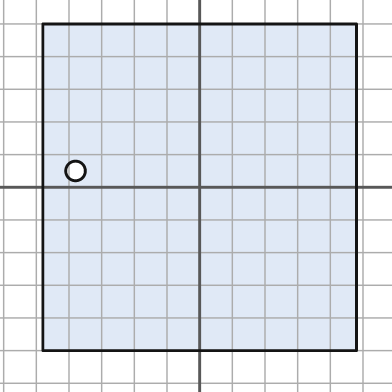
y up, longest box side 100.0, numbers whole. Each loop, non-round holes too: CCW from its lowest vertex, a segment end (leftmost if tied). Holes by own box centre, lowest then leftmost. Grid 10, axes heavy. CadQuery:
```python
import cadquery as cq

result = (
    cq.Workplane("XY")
    .moveTo(-48.0, -50.0)
    .lineTo(48.0, -50.0)
    .lineTo(48.0, 50.0)
    .lineTo(-48.0, 50.0)
    .close()
    .moveTo(-38.0, 5.0)
    .circle(3.0)
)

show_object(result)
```